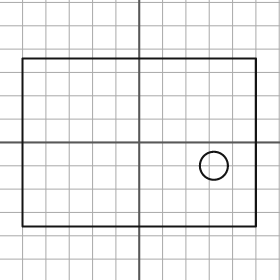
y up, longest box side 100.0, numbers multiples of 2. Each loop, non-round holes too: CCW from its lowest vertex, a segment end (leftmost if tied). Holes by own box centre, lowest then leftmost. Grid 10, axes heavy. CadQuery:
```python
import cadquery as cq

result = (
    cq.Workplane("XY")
    .moveTo(-50.0, -36.0)
    .lineTo(50.0, -36.0)
    .lineTo(50.0, 36.0)
    .lineTo(-50.0, 36.0)
    .close()
    .moveTo(32.0, -10.0)
    .circle(6.0)
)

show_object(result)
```